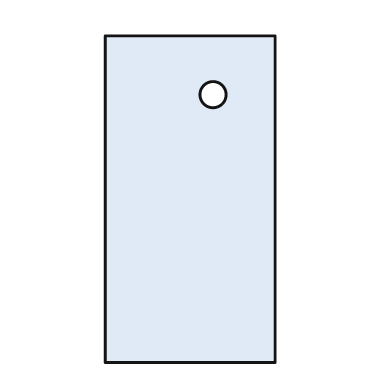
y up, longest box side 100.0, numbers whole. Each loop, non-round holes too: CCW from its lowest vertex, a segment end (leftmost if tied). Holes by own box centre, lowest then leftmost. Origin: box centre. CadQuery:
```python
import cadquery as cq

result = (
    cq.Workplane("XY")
    .moveTo(-26.0, -50.0)
    .lineTo(26.0, -50.0)
    .lineTo(26.0, 50.0)
    .lineTo(-26.0, 50.0)
    .close()
    .moveTo(7.0, 32.0)
    .circle(4.0)
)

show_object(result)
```